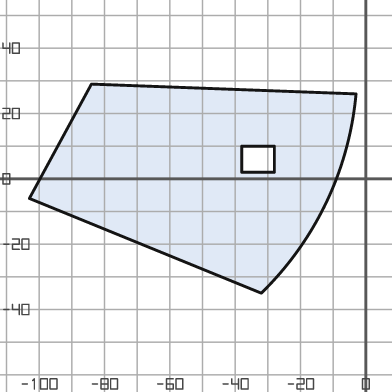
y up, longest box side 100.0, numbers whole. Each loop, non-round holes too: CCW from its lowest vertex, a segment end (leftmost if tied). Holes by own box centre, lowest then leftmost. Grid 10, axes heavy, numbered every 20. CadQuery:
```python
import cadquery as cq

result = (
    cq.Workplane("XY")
    .moveTo(-32.0, -35.0)
    .threePointArc((-12.0, -7.0), (-3.0, 26.0))
    .lineTo(-84.0, 29.0)
    .lineTo(-103.0, -6.0)
    .close()
    .moveTo(-38.0, 2.0)
    .lineTo(-28.0, 2.0)
    .lineTo(-28.0, 10.0)
    .lineTo(-38.0, 10.0)
    .close()
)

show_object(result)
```